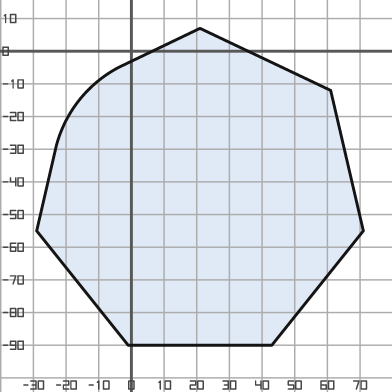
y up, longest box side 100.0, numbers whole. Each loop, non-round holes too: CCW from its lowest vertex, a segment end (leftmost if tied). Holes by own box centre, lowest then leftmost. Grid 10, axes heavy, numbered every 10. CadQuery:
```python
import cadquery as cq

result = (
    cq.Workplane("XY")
    .moveTo(-1.0, -90.0)
    .lineTo(43.0, -90.0)
    .lineTo(71.0, -55.0)
    .lineTo(61.0, -12.0)
    .lineTo(21.0, 7.0)
    .lineTo(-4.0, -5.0)
    .threePointArc((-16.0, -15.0), (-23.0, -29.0))
    .lineTo(-29.0, -55.0)
    .close()
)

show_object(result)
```